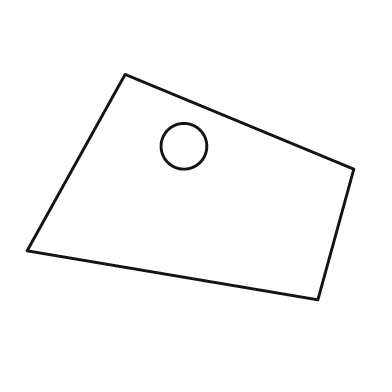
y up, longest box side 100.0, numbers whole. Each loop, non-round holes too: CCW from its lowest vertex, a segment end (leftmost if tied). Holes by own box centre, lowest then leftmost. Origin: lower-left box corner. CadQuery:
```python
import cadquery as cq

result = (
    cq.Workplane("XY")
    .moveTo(89.0, 0.0)
    .lineTo(100.0, 40.0)
    .lineTo(30.0, 69.0)
    .lineTo(0.0, 15.0)
    .close()
    .moveTo(48.0, 47.0)
    .circle(7.0)
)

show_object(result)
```